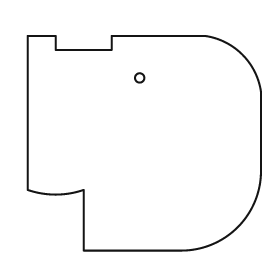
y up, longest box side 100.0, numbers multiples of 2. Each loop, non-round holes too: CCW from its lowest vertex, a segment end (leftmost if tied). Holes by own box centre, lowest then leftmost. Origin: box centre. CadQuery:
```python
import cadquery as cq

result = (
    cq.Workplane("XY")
    .moveTo(-26.0, -46.0)
    .lineTo(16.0, -46.0)
    .threePointArc((40.0, -36.0), (50.0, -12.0))
    .lineTo(50.0, 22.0)
    .threePointArc((42.0, 38.0), (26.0, 46.0))
    .lineTo(-14.0, 46.0)
    .lineTo(-14.0, 40.0)
    .lineTo(-38.0, 40.0)
    .lineTo(-38.0, 46.0)
    .lineTo(-50.0, 46.0)
    .lineTo(-50.0, -20.0)
    .threePointArc((-38.0, -22.0), (-26.0, -20.0))
    .close()
    .moveTo(-2.0, 28.0)
    .circle(2.0)
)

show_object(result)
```